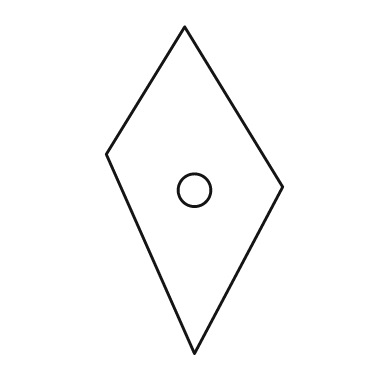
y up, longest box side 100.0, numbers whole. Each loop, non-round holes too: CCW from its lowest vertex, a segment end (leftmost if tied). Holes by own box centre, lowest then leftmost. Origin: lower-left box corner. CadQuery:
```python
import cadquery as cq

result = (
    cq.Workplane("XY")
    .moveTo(27.0, 0.0)
    .lineTo(54.0, 51.0)
    .lineTo(24.0, 100.0)
    .lineTo(0.0, 61.0)
    .close()
    .moveTo(27.0, 50.0)
    .circle(5.0)
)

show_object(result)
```